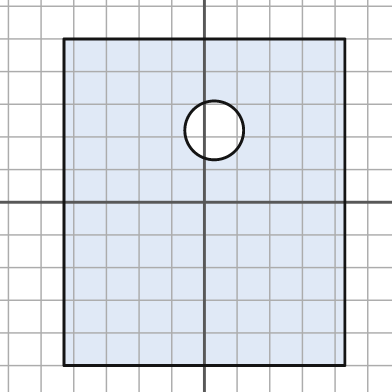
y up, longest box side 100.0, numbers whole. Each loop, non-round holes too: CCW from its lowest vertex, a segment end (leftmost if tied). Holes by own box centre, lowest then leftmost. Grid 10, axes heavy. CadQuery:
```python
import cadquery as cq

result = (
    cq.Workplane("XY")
    .moveTo(-43.0, -50.0)
    .lineTo(43.0, -50.0)
    .lineTo(43.0, 50.0)
    .lineTo(-43.0, 50.0)
    .close()
    .moveTo(3.0, 22.0)
    .circle(9.0)
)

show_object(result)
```